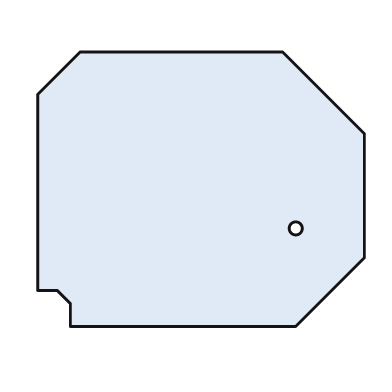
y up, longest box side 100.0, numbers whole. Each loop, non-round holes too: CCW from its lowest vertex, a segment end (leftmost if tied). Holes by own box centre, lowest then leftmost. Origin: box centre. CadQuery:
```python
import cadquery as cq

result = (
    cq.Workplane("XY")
    .moveTo(-40.0, -42.0)
    .lineTo(29.0, -42.0)
    .lineTo(50.0, -21.0)
    .lineTo(50.0, 17.0)
    .lineTo(25.0, 42.0)
    .lineTo(-37.0, 42.0)
    .lineTo(-50.0, 29.0)
    .lineTo(-50.0, -31.0)
    .lineTo(-44.0, -31.0)
    .lineTo(-40.0, -35.0)
    .close()
    .moveTo(29.0, -12.0)
    .circle(2.0)
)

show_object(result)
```